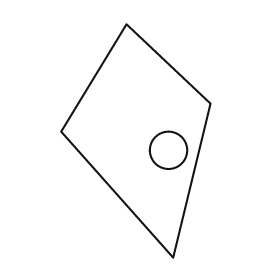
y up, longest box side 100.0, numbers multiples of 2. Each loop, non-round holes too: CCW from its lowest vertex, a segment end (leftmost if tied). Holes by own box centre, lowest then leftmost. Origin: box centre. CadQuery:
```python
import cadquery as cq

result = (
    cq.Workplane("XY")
    .moveTo(16.0, -50.0)
    .lineTo(32.0, 16.0)
    .lineTo(-4.0, 50.0)
    .lineTo(-32.0, 4.0)
    .close()
    .moveTo(14.0, -4.0)
    .circle(8.0)
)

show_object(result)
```